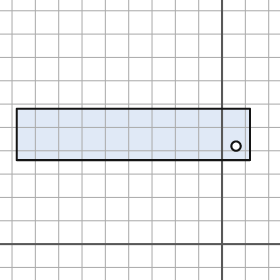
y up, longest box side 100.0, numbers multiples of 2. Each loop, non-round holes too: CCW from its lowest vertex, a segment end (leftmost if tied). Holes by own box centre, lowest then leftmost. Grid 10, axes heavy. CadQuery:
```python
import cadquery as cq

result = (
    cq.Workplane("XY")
    .moveTo(-88.0, 36.0)
    .lineTo(12.0, 36.0)
    .lineTo(12.0, 58.0)
    .lineTo(-88.0, 58.0)
    .close()
    .moveTo(6.0, 42.0)
    .circle(2.0)
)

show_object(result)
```